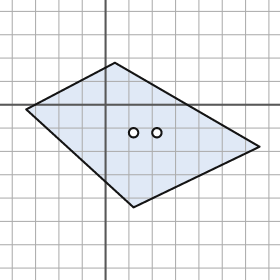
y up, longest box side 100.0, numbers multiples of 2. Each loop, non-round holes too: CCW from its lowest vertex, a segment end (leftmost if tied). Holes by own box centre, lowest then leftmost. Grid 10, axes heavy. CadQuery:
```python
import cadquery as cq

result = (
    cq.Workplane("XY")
    .moveTo(12.0, -44.0)
    .lineTo(66.0, -18.0)
    .lineTo(4.0, 18.0)
    .lineTo(-34.0, -2.0)
    .close()
    .moveTo(12.0, -12.0)
    .circle(2.0)
    .moveTo(22.0, -12.0)
    .circle(2.0)
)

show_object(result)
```